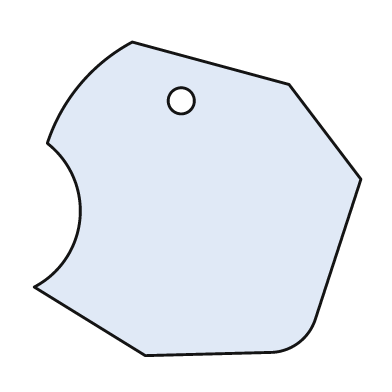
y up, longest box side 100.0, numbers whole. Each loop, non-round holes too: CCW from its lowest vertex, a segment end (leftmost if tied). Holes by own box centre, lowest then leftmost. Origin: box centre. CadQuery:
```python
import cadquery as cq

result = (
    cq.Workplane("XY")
    .moveTo(-16.0, -48.0)
    .lineTo(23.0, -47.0)
    .threePointArc((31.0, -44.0), (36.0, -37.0))
    .lineTo(50.0, 6.0)
    .lineTo(28.0, 35.0)
    .lineTo(-20.0, 48.0)
    .threePointArc((-36.0, 35.0), (-46.0, 17.0))
    .threePointArc((-36.0, -6.0), (-50.0, -27.0))
    .close()
    .moveTo(-5.0, 30.0)
    .circle(4.0)
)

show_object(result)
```